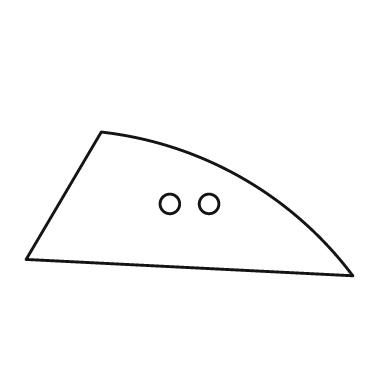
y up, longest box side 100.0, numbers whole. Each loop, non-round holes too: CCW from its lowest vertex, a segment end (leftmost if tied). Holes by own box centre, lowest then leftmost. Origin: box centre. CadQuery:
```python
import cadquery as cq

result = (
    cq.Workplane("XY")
    .moveTo(50.0, -22.0)
    .threePointArc((16.0, 8.0), (-27.0, 22.0))
    .lineTo(-50.0, -17.0)
    .close()
    .moveTo(-6.0, 0.0)
    .circle(3.0)
    .moveTo(6.0, 0.0)
    .circle(3.0)
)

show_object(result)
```